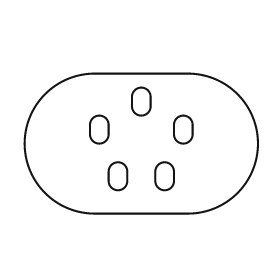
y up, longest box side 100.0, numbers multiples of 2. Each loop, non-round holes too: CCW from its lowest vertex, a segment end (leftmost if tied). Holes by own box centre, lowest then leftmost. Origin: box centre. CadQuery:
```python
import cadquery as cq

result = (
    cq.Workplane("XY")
    .moveTo(-20.0, -30.0)
    .lineTo(20.0, -30.0)
    .threePointArc((50.0, 0.0), (20.0, 30.0))
    .lineTo(-20.0, 30.0)
    .threePointArc((-50.0, 0.0), (-20.0, -30.0))
    .close()
    .moveTo(-14.0, -16.0)
    .threePointArc((-10.0, -20.0), (-6.0, -16.0))
    .lineTo(-6.0, -12.0)
    .threePointArc((-10.0, -8.0), (-14.0, -12.0))
    .close()
    .moveTo(6.0, -16.0)
    .threePointArc((10.0, -20.0), (14.0, -16.0))
    .lineTo(14.0, -12.0)
    .threePointArc((10.0, -8.0), (6.0, -12.0))
    .close()
    .moveTo(-22.0, 4.0)
    .threePointArc((-18.0, 0.0), (-14.0, 4.0))
    .lineTo(-14.0, 8.0)
    .threePointArc((-18.0, 12.0), (-22.0, 8.0))
    .close()
    .moveTo(14.0, 4.0)
    .threePointArc((18.0, 0.0), (22.0, 4.0))
    .lineTo(22.0, 8.0)
    .threePointArc((18.0, 12.0), (14.0, 8.0))
    .close()
    .moveTo(-4.0, 16.0)
    .threePointArc((0.0, 12.0), (4.0, 16.0))
    .lineTo(4.0, 20.0)
    .threePointArc((0.0, 24.0), (-4.0, 20.0))
    .close()
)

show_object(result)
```